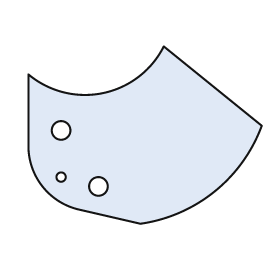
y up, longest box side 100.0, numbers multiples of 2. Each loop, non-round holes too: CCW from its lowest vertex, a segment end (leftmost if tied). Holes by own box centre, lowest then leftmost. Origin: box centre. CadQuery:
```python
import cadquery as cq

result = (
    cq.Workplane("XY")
    .moveTo(-2.0, -38.0)
    .threePointArc((30.0, -24.0), (50.0, 4.0))
    .lineTo(8.0, 38.0)
    .threePointArc((-18.0, 18.0), (-50.0, 26.0))
    .lineTo(-50.0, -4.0)
    .threePointArc((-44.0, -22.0), (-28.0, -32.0))
    .close()
    .moveTo(-20.0, -22.0)
    .circle(4.0)
    .moveTo(-36.0, -18.0)
    .circle(2.0)
    .moveTo(-36.0, 2.0)
    .circle(4.0)
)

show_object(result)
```